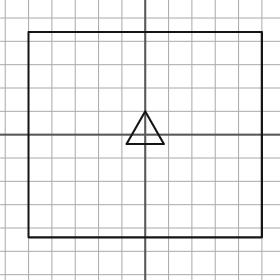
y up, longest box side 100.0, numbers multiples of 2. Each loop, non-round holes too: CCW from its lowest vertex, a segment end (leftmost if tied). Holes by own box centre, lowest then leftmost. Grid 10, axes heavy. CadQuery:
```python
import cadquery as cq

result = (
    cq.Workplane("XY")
    .moveTo(-50.0, -44.0)
    .lineTo(50.0, -44.0)
    .lineTo(50.0, 44.0)
    .lineTo(-50.0, 44.0)
    .close()
    .moveTo(-8.0, -4.0)
    .lineTo(8.0, -4.0)
    .lineTo(0.0, 10.0)
    .close()
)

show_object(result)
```